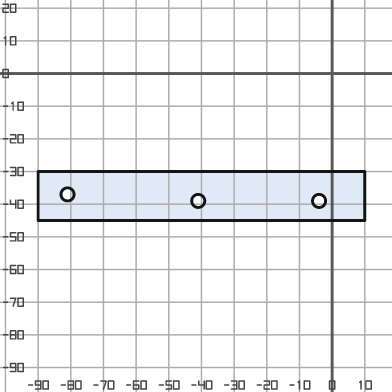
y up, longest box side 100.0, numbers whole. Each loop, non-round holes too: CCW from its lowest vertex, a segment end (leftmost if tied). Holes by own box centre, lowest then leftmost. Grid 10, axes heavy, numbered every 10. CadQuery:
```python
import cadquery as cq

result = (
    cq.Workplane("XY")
    .moveTo(-90.0, -45.0)
    .lineTo(10.0, -45.0)
    .lineTo(10.0, -30.0)
    .lineTo(-90.0, -30.0)
    .close()
    .moveTo(-41.0, -39.0)
    .circle(2.0)
    .moveTo(-4.0, -39.0)
    .circle(2.0)
    .moveTo(-81.0, -37.0)
    .circle(2.0)
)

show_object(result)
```